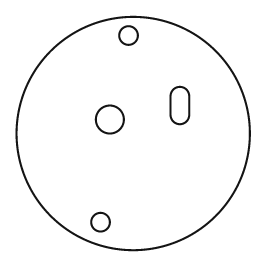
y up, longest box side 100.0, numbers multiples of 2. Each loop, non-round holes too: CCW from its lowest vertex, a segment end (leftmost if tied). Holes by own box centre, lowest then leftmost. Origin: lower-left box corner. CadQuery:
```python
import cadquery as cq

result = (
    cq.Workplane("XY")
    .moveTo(50.0, 50.0)
    .circle(50.0)
    .moveTo(36.0, 12.0)
    .circle(4.0)
    .moveTo(40.0, 56.0)
    .circle(6.0)
    .moveTo(66.0, 58.0)
    .threePointArc((70.0, 54.0), (74.0, 58.0))
    .lineTo(74.0, 66.0)
    .threePointArc((70.0, 70.0), (66.0, 66.0))
    .close()
    .moveTo(48.0, 92.0)
    .circle(4.0)
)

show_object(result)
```